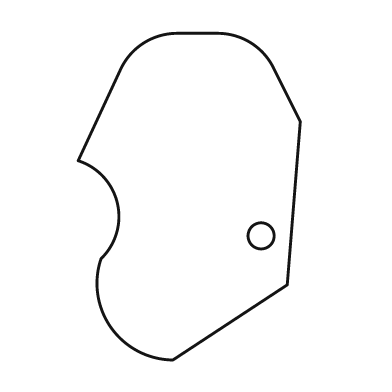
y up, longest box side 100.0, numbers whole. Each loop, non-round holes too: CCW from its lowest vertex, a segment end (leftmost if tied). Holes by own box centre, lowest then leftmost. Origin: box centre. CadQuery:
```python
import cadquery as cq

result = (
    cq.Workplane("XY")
    .moveTo(-5.0, -50.0)
    .lineTo(30.0, -27.0)
    .lineTo(34.0, 23.0)
    .lineTo(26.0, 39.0)
    .threePointArc((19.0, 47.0), (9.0, 50.0))
    .lineTo(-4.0, 50.0)
    .threePointArc((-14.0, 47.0), (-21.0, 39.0))
    .lineTo(-34.0, 11.0)
    .threePointArc((-22.0, -2.0), (-27.0, -19.0))
    .threePointArc((-24.0, -40.0), (-5.0, -50.0))
    .close()
    .moveTo(22.0, -12.0)
    .circle(4.0)
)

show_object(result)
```